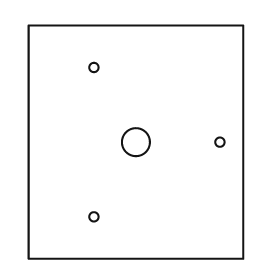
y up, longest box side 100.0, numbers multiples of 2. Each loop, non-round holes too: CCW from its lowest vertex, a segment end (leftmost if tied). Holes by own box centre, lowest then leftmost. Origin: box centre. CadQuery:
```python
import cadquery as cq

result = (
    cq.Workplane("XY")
    .moveTo(-46.0, -50.0)
    .lineTo(46.0, -50.0)
    .lineTo(46.0, 50.0)
    .lineTo(-46.0, 50.0)
    .close()
    .moveTo(-18.0, -32.0)
    .circle(2.0)
    .moveTo(0.0, 0.0)
    .circle(6.0)
    .moveTo(36.0, 0.0)
    .circle(2.0)
    .moveTo(-18.0, 32.0)
    .circle(2.0)
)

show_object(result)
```